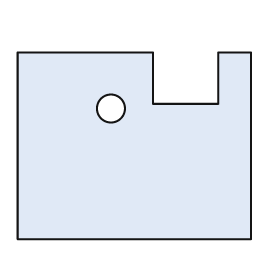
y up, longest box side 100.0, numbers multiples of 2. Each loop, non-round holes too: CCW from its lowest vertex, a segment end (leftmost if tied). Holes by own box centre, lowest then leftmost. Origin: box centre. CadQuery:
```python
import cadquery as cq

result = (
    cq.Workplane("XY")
    .moveTo(-50.0, -40.0)
    .lineTo(50.0, -40.0)
    .lineTo(50.0, 40.0)
    .lineTo(36.0, 40.0)
    .lineTo(36.0, 18.0)
    .lineTo(8.0, 18.0)
    .lineTo(8.0, 40.0)
    .lineTo(-50.0, 40.0)
    .close()
    .moveTo(-10.0, 16.0)
    .circle(6.0)
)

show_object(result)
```